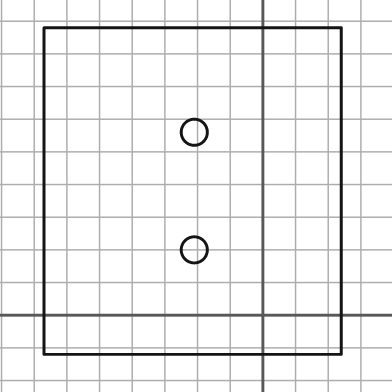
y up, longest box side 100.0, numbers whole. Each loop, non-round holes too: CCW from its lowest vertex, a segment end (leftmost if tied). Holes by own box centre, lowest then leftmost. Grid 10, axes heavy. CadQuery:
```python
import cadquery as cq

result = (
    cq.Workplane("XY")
    .moveTo(-67.0, -12.0)
    .lineTo(24.0, -12.0)
    .lineTo(24.0, 88.0)
    .lineTo(-67.0, 88.0)
    .close()
    .moveTo(-21.0, 20.0)
    .circle(4.0)
    .moveTo(-21.0, 56.0)
    .circle(4.0)
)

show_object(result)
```